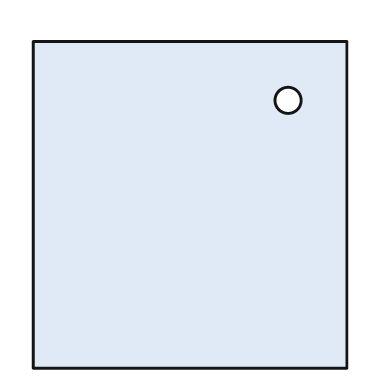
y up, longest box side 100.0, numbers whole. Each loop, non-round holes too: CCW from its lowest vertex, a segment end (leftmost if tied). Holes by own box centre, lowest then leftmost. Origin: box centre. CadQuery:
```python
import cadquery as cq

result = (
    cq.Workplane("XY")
    .moveTo(-48.0, -50.0)
    .lineTo(48.0, -50.0)
    .lineTo(48.0, 50.0)
    .lineTo(-48.0, 50.0)
    .close()
    .moveTo(30.0, 32.0)
    .circle(4.0)
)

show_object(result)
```